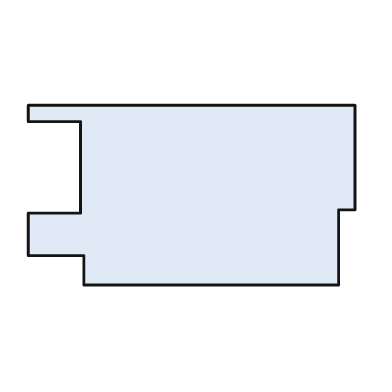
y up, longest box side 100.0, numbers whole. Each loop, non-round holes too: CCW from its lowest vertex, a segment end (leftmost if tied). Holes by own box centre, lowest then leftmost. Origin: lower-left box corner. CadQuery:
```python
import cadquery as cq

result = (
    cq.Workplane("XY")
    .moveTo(17.0, 0.0)
    .lineTo(95.0, 0.0)
    .lineTo(95.0, 23.0)
    .lineTo(100.0, 23.0)
    .lineTo(100.0, 55.0)
    .lineTo(0.0, 55.0)
    .lineTo(0.0, 50.0)
    .lineTo(16.0, 50.0)
    .lineTo(16.0, 22.0)
    .lineTo(0.0, 22.0)
    .lineTo(0.0, 9.0)
    .lineTo(17.0, 9.0)
    .close()
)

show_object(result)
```